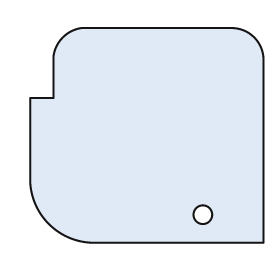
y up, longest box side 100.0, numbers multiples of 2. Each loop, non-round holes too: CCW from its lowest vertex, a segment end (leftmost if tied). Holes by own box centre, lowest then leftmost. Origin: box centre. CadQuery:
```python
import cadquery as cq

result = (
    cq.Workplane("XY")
    .moveTo(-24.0, -46.0)
    .lineTo(50.0, -46.0)
    .lineTo(50.0, 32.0)
    .threePointArc((46.0, 42.0), (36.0, 46.0))
    .lineTo(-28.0, 46.0)
    .threePointArc((-36.0, 42.0), (-40.0, 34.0))
    .lineTo(-40.0, 16.0)
    .lineTo(-50.0, 16.0)
    .lineTo(-50.0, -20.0)
    .threePointArc((-42.0, -38.0), (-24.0, -46.0))
    .close()
    .moveTo(24.0, -34.0)
    .circle(4.0)
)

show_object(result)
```